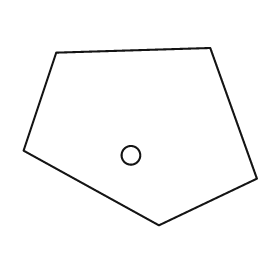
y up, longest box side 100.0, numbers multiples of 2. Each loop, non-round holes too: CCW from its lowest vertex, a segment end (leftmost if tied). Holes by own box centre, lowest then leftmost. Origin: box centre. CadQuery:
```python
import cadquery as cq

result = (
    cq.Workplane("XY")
    .moveTo(8.0, -38.0)
    .lineTo(50.0, -18.0)
    .lineTo(30.0, 38.0)
    .lineTo(-36.0, 36.0)
    .lineTo(-50.0, -6.0)
    .close()
    .moveTo(-4.0, -8.0)
    .circle(4.0)
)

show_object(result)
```